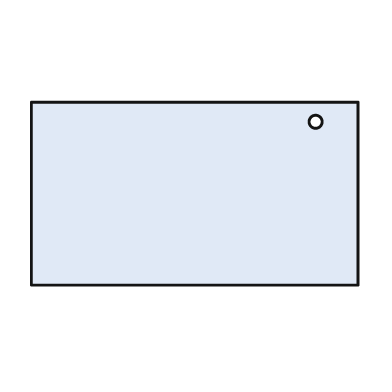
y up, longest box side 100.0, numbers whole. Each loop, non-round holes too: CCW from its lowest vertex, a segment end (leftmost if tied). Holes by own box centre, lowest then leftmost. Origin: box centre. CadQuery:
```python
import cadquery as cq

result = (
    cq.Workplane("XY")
    .moveTo(-50.0, -28.0)
    .lineTo(50.0, -28.0)
    .lineTo(50.0, 28.0)
    .lineTo(-50.0, 28.0)
    .close()
    .moveTo(37.0, 22.0)
    .circle(2.0)
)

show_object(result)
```